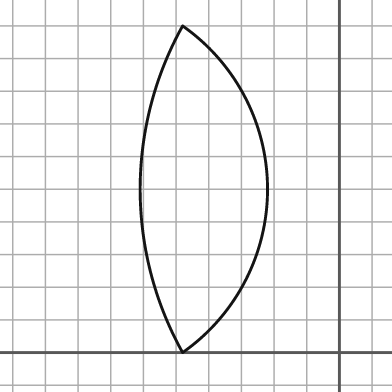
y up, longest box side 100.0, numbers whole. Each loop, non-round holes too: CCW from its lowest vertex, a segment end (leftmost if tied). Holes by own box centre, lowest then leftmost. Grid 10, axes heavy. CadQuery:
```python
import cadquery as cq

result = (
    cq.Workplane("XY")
    .moveTo(-48.0, 0.0)
    .threePointArc((-22.0, 50.0), (-48.0, 100.0))
    .threePointArc((-61.0, 50.0), (-48.0, 0.0))
    .close()
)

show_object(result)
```